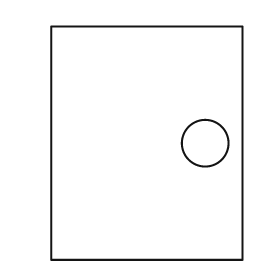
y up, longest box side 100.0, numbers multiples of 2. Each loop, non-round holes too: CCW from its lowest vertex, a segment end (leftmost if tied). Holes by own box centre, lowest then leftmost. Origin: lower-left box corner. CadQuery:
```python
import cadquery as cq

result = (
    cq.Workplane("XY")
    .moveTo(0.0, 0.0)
    .lineTo(82.0, 0.0)
    .lineTo(82.0, 100.0)
    .lineTo(0.0, 100.0)
    .close()
    .moveTo(66.0, 50.0)
    .circle(10.0)
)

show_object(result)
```